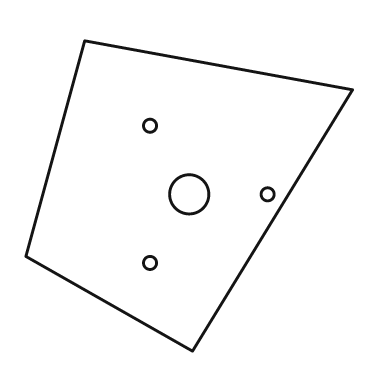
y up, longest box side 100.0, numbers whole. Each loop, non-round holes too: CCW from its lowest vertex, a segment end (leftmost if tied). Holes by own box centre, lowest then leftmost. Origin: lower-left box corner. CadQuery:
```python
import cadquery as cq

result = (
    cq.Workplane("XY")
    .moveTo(51.0, 0.0)
    .lineTo(100.0, 80.0)
    .lineTo(18.0, 95.0)
    .lineTo(0.0, 29.0)
    .close()
    .moveTo(38.0, 27.0)
    .circle(2.0)
    .moveTo(50.0, 48.0)
    .circle(6.0)
    .moveTo(74.0, 48.0)
    .circle(2.0)
    .moveTo(38.0, 69.0)
    .circle(2.0)
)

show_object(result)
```